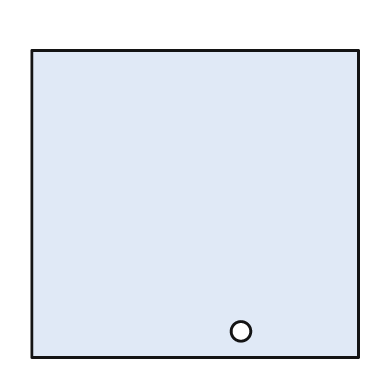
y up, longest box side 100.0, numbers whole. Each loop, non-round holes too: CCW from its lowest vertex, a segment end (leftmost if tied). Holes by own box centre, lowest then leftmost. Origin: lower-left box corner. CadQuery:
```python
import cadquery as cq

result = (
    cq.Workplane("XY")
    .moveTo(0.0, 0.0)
    .lineTo(100.0, 0.0)
    .lineTo(100.0, 94.0)
    .lineTo(0.0, 94.0)
    .close()
    .moveTo(64.0, 8.0)
    .circle(3.0)
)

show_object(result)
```